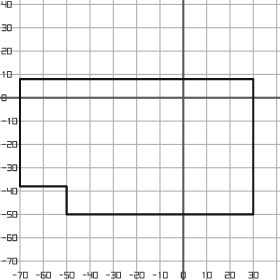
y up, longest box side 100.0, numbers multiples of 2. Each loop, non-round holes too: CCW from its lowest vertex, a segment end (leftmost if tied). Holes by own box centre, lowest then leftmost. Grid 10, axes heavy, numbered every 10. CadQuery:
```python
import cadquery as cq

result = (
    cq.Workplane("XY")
    .moveTo(-50.0, -50.0)
    .lineTo(30.0, -50.0)
    .lineTo(30.0, 8.0)
    .lineTo(-70.0, 8.0)
    .lineTo(-70.0, -38.0)
    .lineTo(-50.0, -38.0)
    .close()
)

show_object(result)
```